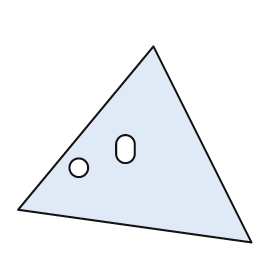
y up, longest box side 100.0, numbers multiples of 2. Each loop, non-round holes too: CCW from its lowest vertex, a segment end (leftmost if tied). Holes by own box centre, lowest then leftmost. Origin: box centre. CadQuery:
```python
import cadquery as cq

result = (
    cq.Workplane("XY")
    .moveTo(50.0, -42.0)
    .lineTo(8.0, 42.0)
    .lineTo(-50.0, -28.0)
    .close()
    .moveTo(-24.0, -10.0)
    .circle(4.0)
    .moveTo(-8.0, -4.0)
    .threePointArc((-4.0, -8.0), (0.0, -4.0))
    .lineTo(0.0, 0.0)
    .threePointArc((-4.0, 4.0), (-8.0, 0.0))
    .close()
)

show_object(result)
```